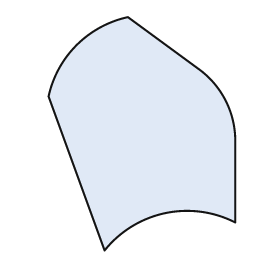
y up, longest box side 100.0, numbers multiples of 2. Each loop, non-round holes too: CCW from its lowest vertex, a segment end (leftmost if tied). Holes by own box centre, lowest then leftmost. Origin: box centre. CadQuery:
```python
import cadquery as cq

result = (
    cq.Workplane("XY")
    .moveTo(-16.0, -50.0)
    .threePointArc((10.0, -34.0), (40.0, -38.0))
    .lineTo(40.0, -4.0)
    .threePointArc((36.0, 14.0), (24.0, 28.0))
    .lineTo(-6.0, 50.0)
    .threePointArc((-28.0, 38.0), (-40.0, 16.0))
    .close()
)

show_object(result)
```